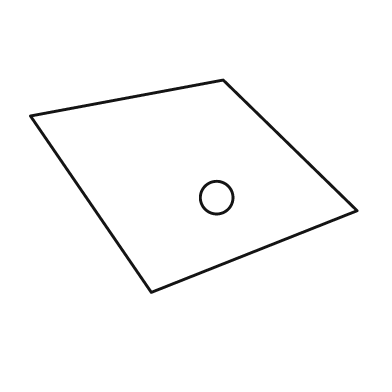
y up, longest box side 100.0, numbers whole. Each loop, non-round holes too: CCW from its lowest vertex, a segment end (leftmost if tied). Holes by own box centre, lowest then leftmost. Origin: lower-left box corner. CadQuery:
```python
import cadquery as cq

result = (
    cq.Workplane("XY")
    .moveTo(37.0, 0.0)
    .lineTo(100.0, 25.0)
    .lineTo(59.0, 65.0)
    .lineTo(0.0, 54.0)
    .close()
    .moveTo(57.0, 29.0)
    .circle(5.0)
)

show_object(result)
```